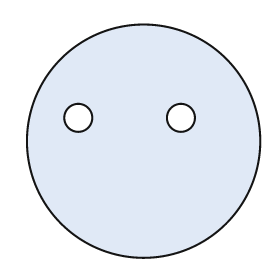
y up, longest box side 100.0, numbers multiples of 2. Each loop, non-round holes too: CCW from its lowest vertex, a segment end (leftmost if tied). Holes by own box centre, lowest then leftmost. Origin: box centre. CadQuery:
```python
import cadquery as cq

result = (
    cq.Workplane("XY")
    .moveTo(0.0, 0.0)
    .circle(50.0)
    .moveTo(-28.0, 10.0)
    .circle(6.0)
    .moveTo(16.0, 10.0)
    .circle(6.0)
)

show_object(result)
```